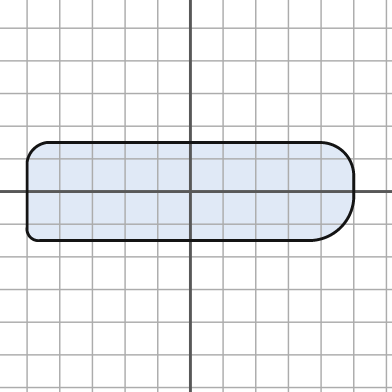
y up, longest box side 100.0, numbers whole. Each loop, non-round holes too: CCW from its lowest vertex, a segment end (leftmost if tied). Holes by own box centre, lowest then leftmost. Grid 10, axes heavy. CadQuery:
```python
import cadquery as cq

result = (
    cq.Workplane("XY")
    .moveTo(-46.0, -15.0)
    .lineTo(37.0, -15.0)
    .threePointArc((46.0, -11.0), (50.0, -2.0))
    .lineTo(50.0, 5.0)
    .threePointArc((47.0, 12.0), (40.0, 15.0))
    .lineTo(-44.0, 15.0)
    .threePointArc((-48.0, 13.0), (-50.0, 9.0))
    .lineTo(-50.0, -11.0)
    .threePointArc((-49.0, -14.0), (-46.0, -15.0))
    .close()
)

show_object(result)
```